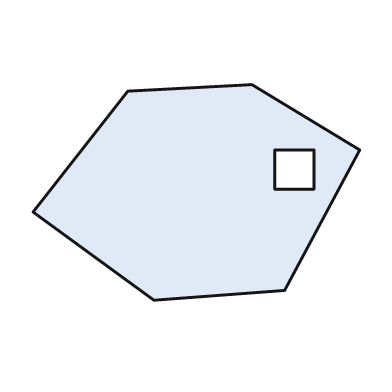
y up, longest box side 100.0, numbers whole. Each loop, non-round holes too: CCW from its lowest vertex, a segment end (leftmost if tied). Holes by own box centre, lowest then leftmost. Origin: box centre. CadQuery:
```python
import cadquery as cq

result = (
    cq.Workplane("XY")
    .moveTo(-13.0, -33.0)
    .lineTo(27.0, -30.0)
    .lineTo(50.0, 13.0)
    .lineTo(17.0, 33.0)
    .lineTo(-21.0, 31.0)
    .lineTo(-50.0, -6.0)
    .close()
    .moveTo(24.0, 1.0)
    .lineTo(36.0, 1.0)
    .lineTo(36.0, 13.0)
    .lineTo(24.0, 13.0)
    .close()
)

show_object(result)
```